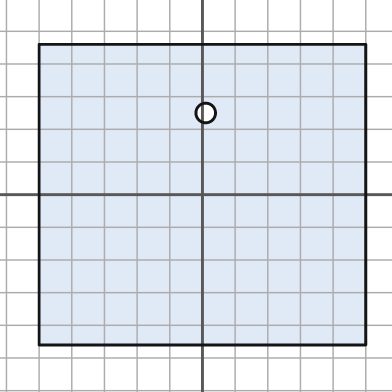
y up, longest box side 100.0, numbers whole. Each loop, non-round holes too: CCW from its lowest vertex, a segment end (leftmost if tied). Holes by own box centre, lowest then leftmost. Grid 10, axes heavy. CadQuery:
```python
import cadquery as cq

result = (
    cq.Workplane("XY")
    .moveTo(-50.0, -46.0)
    .lineTo(50.0, -46.0)
    .lineTo(50.0, 46.0)
    .lineTo(-50.0, 46.0)
    .close()
    .moveTo(1.0, 25.0)
    .circle(3.0)
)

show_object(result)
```